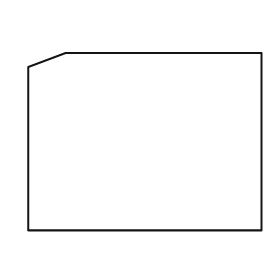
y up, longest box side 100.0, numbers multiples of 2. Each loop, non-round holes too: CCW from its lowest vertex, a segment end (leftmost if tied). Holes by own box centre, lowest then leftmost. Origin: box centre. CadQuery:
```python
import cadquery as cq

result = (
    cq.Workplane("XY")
    .moveTo(-50.0, -38.0)
    .lineTo(50.0, -38.0)
    .lineTo(50.0, 38.0)
    .lineTo(-34.0, 38.0)
    .lineTo(-50.0, 32.0)
    .close()
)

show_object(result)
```